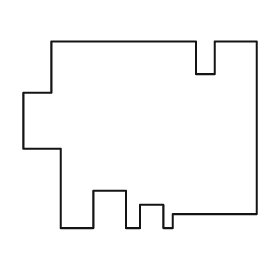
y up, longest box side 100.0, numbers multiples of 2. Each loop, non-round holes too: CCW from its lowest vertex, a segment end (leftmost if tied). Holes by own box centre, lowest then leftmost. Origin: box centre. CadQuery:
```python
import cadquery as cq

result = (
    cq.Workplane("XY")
    .moveTo(-34.0, -40.0)
    .lineTo(-20.0, -40.0)
    .lineTo(-20.0, -24.0)
    .lineTo(-6.0, -24.0)
    .lineTo(-6.0, -40.0)
    .lineTo(0.0, -40.0)
    .lineTo(0.0, -30.0)
    .lineTo(10.0, -30.0)
    .lineTo(10.0, -40.0)
    .lineTo(14.0, -40.0)
    .lineTo(14.0, -34.0)
    .lineTo(50.0, -34.0)
    .lineTo(50.0, 40.0)
    .lineTo(32.0, 40.0)
    .lineTo(32.0, 26.0)
    .lineTo(24.0, 26.0)
    .lineTo(24.0, 40.0)
    .lineTo(-38.0, 40.0)
    .lineTo(-38.0, 18.0)
    .lineTo(-50.0, 18.0)
    .lineTo(-50.0, -6.0)
    .lineTo(-34.0, -6.0)
    .close()
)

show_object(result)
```